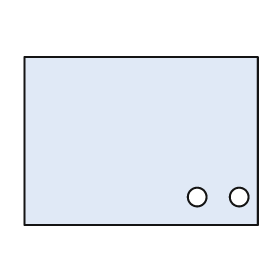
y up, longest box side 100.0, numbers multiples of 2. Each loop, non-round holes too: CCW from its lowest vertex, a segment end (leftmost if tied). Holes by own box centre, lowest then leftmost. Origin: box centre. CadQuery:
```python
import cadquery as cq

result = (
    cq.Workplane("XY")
    .moveTo(-50.0, -36.0)
    .lineTo(50.0, -36.0)
    .lineTo(50.0, 36.0)
    .lineTo(-50.0, 36.0)
    .close()
    .moveTo(24.0, -24.0)
    .circle(4.0)
    .moveTo(42.0, -24.0)
    .circle(4.0)
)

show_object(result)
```